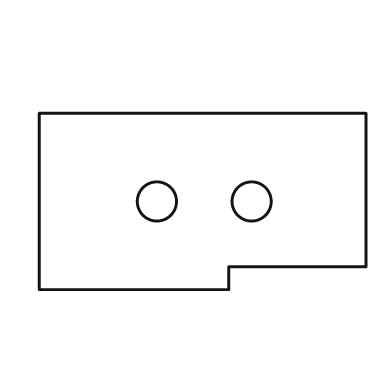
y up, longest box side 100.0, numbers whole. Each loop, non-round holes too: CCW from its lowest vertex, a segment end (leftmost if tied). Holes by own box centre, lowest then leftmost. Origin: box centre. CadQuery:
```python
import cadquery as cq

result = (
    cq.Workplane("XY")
    .moveTo(-50.0, -27.0)
    .lineTo(8.0, -27.0)
    .lineTo(8.0, -20.0)
    .lineTo(50.0, -20.0)
    .lineTo(50.0, 27.0)
    .lineTo(-50.0, 27.0)
    .close()
    .moveTo(-14.0, 0.0)
    .circle(6.0)
    .moveTo(15.0, 0.0)
    .circle(6.0)
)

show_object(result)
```